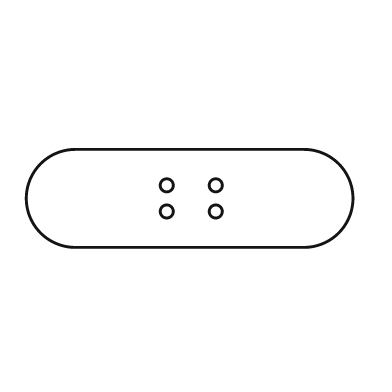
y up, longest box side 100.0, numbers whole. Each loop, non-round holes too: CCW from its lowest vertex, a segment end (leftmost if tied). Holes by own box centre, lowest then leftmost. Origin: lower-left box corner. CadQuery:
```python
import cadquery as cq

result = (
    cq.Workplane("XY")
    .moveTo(15.0, 0.0)
    .lineTo(85.0, 0.0)
    .threePointArc((100.0, 15.0), (85.0, 30.0))
    .lineTo(15.0, 30.0)
    .threePointArc((0.0, 15.0), (15.0, 0.0))
    .close()
    .moveTo(43.0, 11.0)
    .circle(2.0)
    .moveTo(58.0, 11.0)
    .circle(2.0)
    .moveTo(43.0, 19.0)
    .circle(2.0)
    .moveTo(58.0, 19.0)
    .circle(2.0)
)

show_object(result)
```